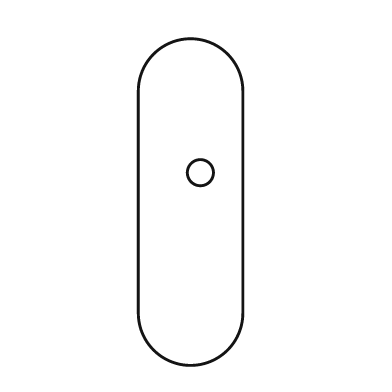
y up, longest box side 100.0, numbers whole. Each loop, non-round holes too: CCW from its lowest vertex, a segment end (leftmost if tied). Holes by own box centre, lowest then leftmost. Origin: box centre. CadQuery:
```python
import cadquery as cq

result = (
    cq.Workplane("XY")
    .moveTo(-16.0, -34.0)
    .threePointArc((0.0, -50.0), (16.0, -34.0))
    .lineTo(16.0, 34.0)
    .threePointArc((0.0, 50.0), (-16.0, 34.0))
    .close()
    .moveTo(3.0, 9.0)
    .circle(4.0)
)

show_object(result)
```